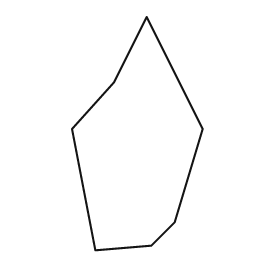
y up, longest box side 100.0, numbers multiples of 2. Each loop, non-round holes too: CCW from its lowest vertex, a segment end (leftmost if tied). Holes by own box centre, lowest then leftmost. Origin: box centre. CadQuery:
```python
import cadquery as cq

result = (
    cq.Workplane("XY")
    .moveTo(-18.0, -50.0)
    .lineTo(6.0, -48.0)
    .lineTo(16.0, -38.0)
    .lineTo(28.0, 2.0)
    .lineTo(4.0, 50.0)
    .lineTo(-10.0, 22.0)
    .lineTo(-28.0, 2.0)
    .close()
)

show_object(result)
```